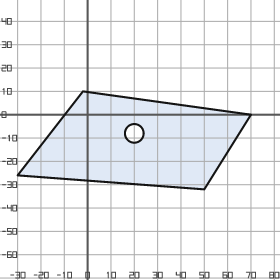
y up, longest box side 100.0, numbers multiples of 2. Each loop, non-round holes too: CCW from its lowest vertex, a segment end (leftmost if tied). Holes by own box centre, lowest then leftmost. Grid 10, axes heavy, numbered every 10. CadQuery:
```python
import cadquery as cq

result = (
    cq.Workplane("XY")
    .moveTo(50.0, -32.0)
    .lineTo(70.0, 0.0)
    .lineTo(-2.0, 10.0)
    .lineTo(-30.0, -26.0)
    .close()
    .moveTo(20.0, -8.0)
    .circle(4.0)
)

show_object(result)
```